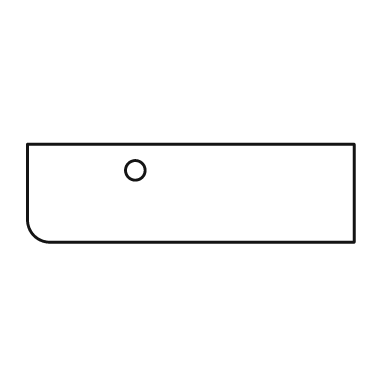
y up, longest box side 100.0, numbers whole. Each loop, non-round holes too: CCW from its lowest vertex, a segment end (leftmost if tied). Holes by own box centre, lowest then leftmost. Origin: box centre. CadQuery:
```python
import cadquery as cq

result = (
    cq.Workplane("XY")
    .moveTo(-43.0, -15.0)
    .lineTo(50.0, -15.0)
    .lineTo(50.0, 15.0)
    .lineTo(-50.0, 15.0)
    .lineTo(-50.0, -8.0)
    .threePointArc((-48.0, -13.0), (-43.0, -15.0))
    .close()
    .moveTo(-17.0, 7.0)
    .circle(3.0)
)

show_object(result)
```